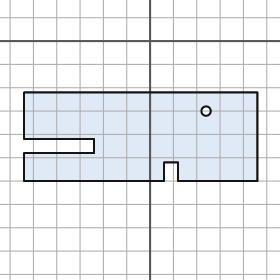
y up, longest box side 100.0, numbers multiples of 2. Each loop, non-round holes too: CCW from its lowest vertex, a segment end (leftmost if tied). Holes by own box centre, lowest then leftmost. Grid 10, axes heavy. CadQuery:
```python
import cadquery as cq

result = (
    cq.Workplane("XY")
    .moveTo(-54.0, -60.0)
    .lineTo(6.0, -60.0)
    .lineTo(6.0, -52.0)
    .lineTo(12.0, -52.0)
    .lineTo(12.0, -60.0)
    .lineTo(46.0, -60.0)
    .lineTo(46.0, -22.0)
    .lineTo(-54.0, -22.0)
    .lineTo(-54.0, -42.0)
    .lineTo(-24.0, -42.0)
    .lineTo(-24.0, -48.0)
    .lineTo(-54.0, -48.0)
    .close()
    .moveTo(24.0, -30.0)
    .circle(2.0)
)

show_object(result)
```